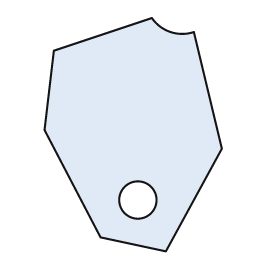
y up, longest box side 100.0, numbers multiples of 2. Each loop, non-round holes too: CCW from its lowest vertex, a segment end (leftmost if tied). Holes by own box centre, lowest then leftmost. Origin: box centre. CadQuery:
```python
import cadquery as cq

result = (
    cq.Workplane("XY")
    .moveTo(14.0, -50.0)
    .lineTo(38.0, -6.0)
    .lineTo(26.0, 44.0)
    .threePointArc((16.0, 44.0), (8.0, 50.0))
    .lineTo(-34.0, 36.0)
    .lineTo(-38.0, 2.0)
    .lineTo(-14.0, -44.0)
    .close()
    .moveTo(2.0, -28.0)
    .circle(8.0)
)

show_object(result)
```